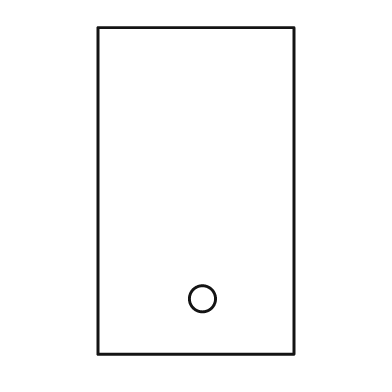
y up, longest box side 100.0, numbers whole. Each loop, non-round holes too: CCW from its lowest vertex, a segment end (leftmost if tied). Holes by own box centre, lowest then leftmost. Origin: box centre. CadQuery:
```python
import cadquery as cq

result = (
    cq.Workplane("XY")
    .moveTo(-30.0, -50.0)
    .lineTo(30.0, -50.0)
    .lineTo(30.0, 50.0)
    .lineTo(-30.0, 50.0)
    .close()
    .moveTo(2.0, -33.0)
    .circle(4.0)
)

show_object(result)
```